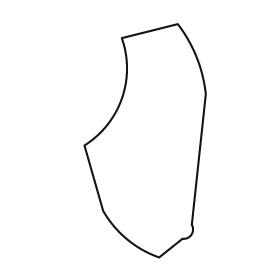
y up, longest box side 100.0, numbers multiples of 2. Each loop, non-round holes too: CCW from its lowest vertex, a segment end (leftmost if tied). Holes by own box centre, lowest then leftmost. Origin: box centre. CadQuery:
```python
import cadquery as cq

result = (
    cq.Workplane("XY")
    .moveTo(6.0, -50.0)
    .lineTo(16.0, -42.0)
    .threePointArc((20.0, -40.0), (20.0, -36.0))
    .lineTo(26.0, 20.0)
    .threePointArc((22.0, 36.0), (14.0, 50.0))
    .lineTo(-10.0, 44.0)
    .threePointArc((-10.0, 18.0), (-26.0, -2.0))
    .lineTo(-18.0, -30.0)
    .threePointArc((-8.0, -42.0), (6.0, -50.0))
    .close()
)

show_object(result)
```